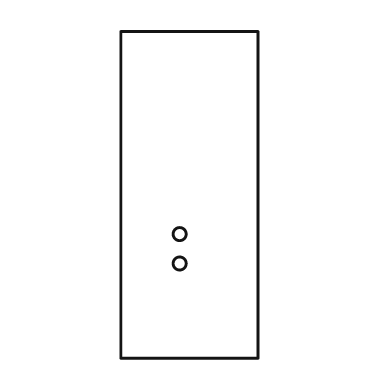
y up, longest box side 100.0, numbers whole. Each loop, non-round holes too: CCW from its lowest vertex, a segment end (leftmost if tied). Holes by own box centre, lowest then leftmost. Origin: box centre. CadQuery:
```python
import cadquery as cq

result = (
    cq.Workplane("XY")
    .moveTo(-21.0, -50.0)
    .lineTo(21.0, -50.0)
    .lineTo(21.0, 50.0)
    .lineTo(-21.0, 50.0)
    .close()
    .moveTo(-3.0, -21.0)
    .circle(2.0)
    .moveTo(-3.0, -12.0)
    .circle(2.0)
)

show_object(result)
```